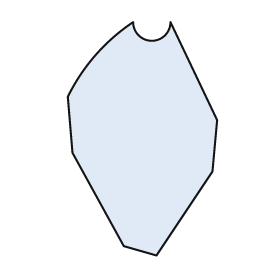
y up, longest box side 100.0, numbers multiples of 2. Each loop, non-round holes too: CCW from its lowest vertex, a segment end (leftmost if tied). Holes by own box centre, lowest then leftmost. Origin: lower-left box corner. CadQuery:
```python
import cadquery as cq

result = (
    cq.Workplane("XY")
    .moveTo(38.0, 0.0)
    .lineTo(62.0, 36.0)
    .lineTo(64.0, 58.0)
    .lineTo(44.0, 100.0)
    .threePointArc((36.0, 92.0), (28.0, 100.0))
    .threePointArc((12.0, 86.0), (0.0, 68.0))
    .lineTo(2.0, 44.0)
    .lineTo(24.0, 4.0)
    .close()
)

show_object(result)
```